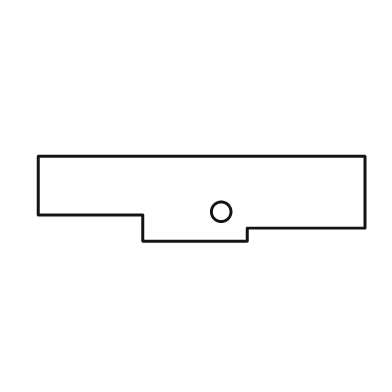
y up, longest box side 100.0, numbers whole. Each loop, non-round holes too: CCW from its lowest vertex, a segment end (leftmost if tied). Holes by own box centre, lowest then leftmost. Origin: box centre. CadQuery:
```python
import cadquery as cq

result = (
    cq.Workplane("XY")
    .moveTo(-18.0, -13.0)
    .lineTo(14.0, -13.0)
    .lineTo(14.0, -9.0)
    .lineTo(50.0, -9.0)
    .lineTo(50.0, 13.0)
    .lineTo(-50.0, 13.0)
    .lineTo(-50.0, -5.0)
    .lineTo(-18.0, -5.0)
    .close()
    .moveTo(6.0, -4.0)
    .circle(3.0)
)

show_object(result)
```